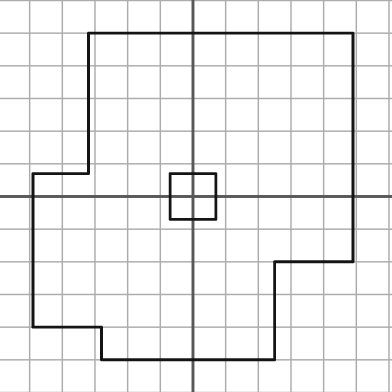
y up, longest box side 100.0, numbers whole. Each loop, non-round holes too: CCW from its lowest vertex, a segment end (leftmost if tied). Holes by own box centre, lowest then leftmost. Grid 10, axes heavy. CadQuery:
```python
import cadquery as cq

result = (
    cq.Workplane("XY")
    .moveTo(-28.0, -50.0)
    .lineTo(25.0, -50.0)
    .lineTo(25.0, -20.0)
    .lineTo(49.0, -20.0)
    .lineTo(49.0, 50.0)
    .lineTo(-32.0, 50.0)
    .lineTo(-32.0, 7.0)
    .lineTo(-49.0, 7.0)
    .lineTo(-49.0, -40.0)
    .lineTo(-28.0, -40.0)
    .close()
    .moveTo(-7.0, -7.0)
    .lineTo(7.0, -7.0)
    .lineTo(7.0, 7.0)
    .lineTo(-7.0, 7.0)
    .close()
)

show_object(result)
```